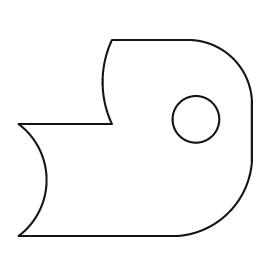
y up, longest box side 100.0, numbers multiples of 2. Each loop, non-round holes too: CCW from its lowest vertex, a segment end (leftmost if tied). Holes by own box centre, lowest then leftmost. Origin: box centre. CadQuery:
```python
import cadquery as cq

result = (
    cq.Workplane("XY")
    .moveTo(-50.0, -42.0)
    .lineTo(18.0, -42.0)
    .threePointArc((40.0, -32.0), (50.0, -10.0))
    .lineTo(50.0, 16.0)
    .threePointArc((42.0, 34.0), (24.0, 42.0))
    .lineTo(-10.0, 42.0)
    .threePointArc((-14.0, 24.0), (-10.0, 6.0))
    .lineTo(-50.0, 6.0)
    .threePointArc((-38.0, -18.0), (-50.0, -42.0))
    .close()
    .moveTo(26.0, 8.0)
    .circle(10.0)
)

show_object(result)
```